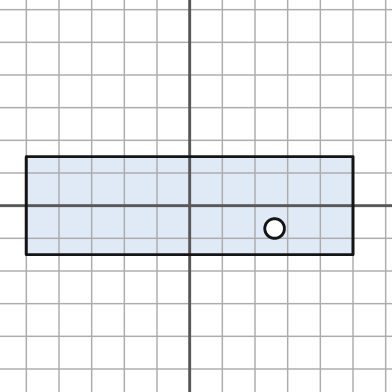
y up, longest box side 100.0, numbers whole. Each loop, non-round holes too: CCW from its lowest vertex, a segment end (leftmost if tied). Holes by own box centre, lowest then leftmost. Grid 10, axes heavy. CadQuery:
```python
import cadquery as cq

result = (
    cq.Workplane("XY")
    .moveTo(-50.0, -15.0)
    .lineTo(50.0, -15.0)
    .lineTo(50.0, 15.0)
    .lineTo(-50.0, 15.0)
    .close()
    .moveTo(26.0, -7.0)
    .circle(3.0)
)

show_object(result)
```